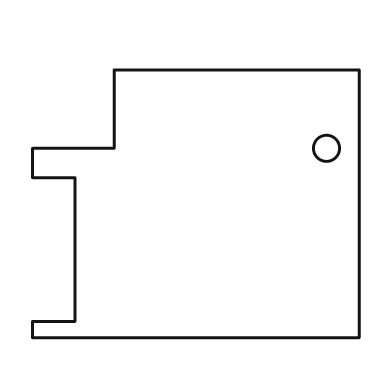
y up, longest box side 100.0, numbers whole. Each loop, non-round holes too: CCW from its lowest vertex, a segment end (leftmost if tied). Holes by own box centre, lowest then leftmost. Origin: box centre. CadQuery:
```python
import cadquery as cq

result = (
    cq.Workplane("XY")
    .moveTo(-50.0, -41.0)
    .lineTo(50.0, -41.0)
    .lineTo(50.0, 41.0)
    .lineTo(-25.0, 41.0)
    .lineTo(-25.0, 17.0)
    .lineTo(-50.0, 17.0)
    .lineTo(-50.0, 8.0)
    .lineTo(-37.0, 8.0)
    .lineTo(-37.0, -36.0)
    .lineTo(-50.0, -36.0)
    .close()
    .moveTo(40.0, 17.0)
    .circle(4.0)
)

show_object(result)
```